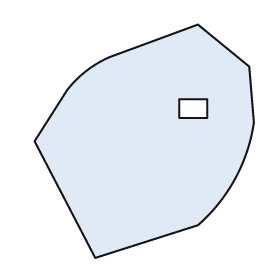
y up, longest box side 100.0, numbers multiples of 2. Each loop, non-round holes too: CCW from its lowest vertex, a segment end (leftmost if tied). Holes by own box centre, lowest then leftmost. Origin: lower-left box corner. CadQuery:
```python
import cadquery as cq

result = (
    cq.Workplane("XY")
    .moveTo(26.0, 0.0)
    .lineTo(70.0, 14.0)
    .threePointArc((86.0, 34.0), (94.0, 58.0))
    .lineTo(92.0, 82.0)
    .lineTo(70.0, 100.0)
    .lineTo(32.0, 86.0)
    .threePointArc((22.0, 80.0), (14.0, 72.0))
    .lineTo(0.0, 50.0)
    .close()
    .moveTo(62.0, 60.0)
    .lineTo(74.0, 60.0)
    .lineTo(74.0, 68.0)
    .lineTo(62.0, 68.0)
    .close()
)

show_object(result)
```